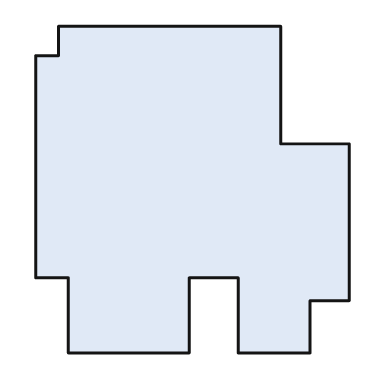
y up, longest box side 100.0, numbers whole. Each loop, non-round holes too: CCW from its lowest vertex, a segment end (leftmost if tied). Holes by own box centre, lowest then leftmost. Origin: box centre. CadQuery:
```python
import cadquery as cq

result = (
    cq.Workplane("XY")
    .moveTo(-38.0, -50.0)
    .lineTo(-1.0, -50.0)
    .lineTo(-1.0, -27.0)
    .lineTo(14.0, -27.0)
    .lineTo(14.0, -50.0)
    .lineTo(36.0, -50.0)
    .lineTo(36.0, -34.0)
    .lineTo(48.0, -34.0)
    .lineTo(48.0, 14.0)
    .lineTo(27.0, 14.0)
    .lineTo(27.0, 50.0)
    .lineTo(-41.0, 50.0)
    .lineTo(-41.0, 41.0)
    .lineTo(-48.0, 41.0)
    .lineTo(-48.0, -27.0)
    .lineTo(-38.0, -27.0)
    .close()
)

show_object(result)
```